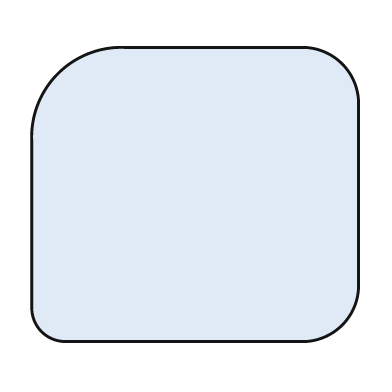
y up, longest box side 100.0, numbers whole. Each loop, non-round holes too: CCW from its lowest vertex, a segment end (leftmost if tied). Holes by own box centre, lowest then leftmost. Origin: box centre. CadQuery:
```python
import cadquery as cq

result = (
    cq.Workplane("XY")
    .moveTo(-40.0, -45.0)
    .lineTo(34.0, -45.0)
    .threePointArc((45.0, -40.0), (50.0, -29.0))
    .lineTo(50.0, 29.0)
    .threePointArc((45.0, 40.0), (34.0, 45.0))
    .lineTo(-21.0, 45.0)
    .threePointArc((-42.0, 37.0), (-50.0, 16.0))
    .lineTo(-50.0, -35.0)
    .threePointArc((-47.0, -42.0), (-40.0, -45.0))
    .close()
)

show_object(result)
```